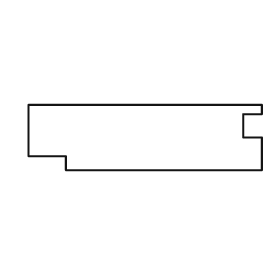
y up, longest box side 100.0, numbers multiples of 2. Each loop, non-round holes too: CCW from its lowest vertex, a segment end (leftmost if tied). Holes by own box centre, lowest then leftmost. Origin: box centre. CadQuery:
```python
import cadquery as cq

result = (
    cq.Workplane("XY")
    .moveTo(-34.0, -14.0)
    .lineTo(50.0, -14.0)
    .lineTo(50.0, 0.0)
    .lineTo(42.0, 0.0)
    .lineTo(42.0, 10.0)
    .lineTo(50.0, 10.0)
    .lineTo(50.0, 14.0)
    .lineTo(-50.0, 14.0)
    .lineTo(-50.0, -8.0)
    .lineTo(-34.0, -8.0)
    .close()
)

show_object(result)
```